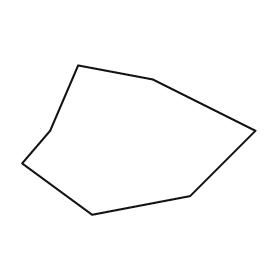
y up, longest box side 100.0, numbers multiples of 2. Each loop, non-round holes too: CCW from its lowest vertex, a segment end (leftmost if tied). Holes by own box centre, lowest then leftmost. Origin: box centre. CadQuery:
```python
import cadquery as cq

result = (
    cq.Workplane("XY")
    .moveTo(-20.0, -32.0)
    .lineTo(22.0, -24.0)
    .lineTo(50.0, 4.0)
    .lineTo(6.0, 26.0)
    .lineTo(-26.0, 32.0)
    .lineTo(-38.0, 4.0)
    .lineTo(-50.0, -10.0)
    .close()
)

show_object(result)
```